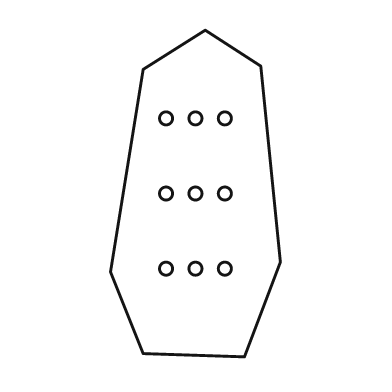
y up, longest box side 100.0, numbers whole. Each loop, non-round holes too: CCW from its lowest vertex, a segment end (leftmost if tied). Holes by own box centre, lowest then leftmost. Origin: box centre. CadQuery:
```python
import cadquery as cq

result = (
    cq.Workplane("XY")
    .moveTo(15.0, -50.0)
    .lineTo(26.0, -21.0)
    .lineTo(20.0, 39.0)
    .lineTo(3.0, 50.0)
    .lineTo(-16.0, 38.0)
    .lineTo(-26.0, -24.0)
    .lineTo(-16.0, -49.0)
    .close()
    .moveTo(-9.0, -23.0)
    .circle(2.0)
    .moveTo(0.0, -23.0)
    .circle(2.0)
    .moveTo(9.0, -23.0)
    .circle(2.0)
    .moveTo(-9.0, 0.0)
    .circle(2.0)
    .moveTo(0.0, 0.0)
    .circle(2.0)
    .moveTo(9.0, 0.0)
    .circle(2.0)
    .moveTo(-9.0, 23.0)
    .circle(2.0)
    .moveTo(0.0, 23.0)
    .circle(2.0)
    .moveTo(9.0, 23.0)
    .circle(2.0)
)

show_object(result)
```